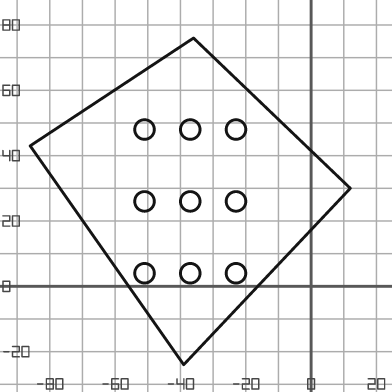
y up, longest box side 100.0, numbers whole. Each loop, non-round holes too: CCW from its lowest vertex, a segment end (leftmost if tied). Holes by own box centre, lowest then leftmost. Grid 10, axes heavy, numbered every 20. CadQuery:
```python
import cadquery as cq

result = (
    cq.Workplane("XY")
    .moveTo(-39.0, -24.0)
    .lineTo(12.0, 30.0)
    .lineTo(-36.0, 76.0)
    .lineTo(-86.0, 43.0)
    .close()
    .moveTo(-51.0, 4.0)
    .circle(3.0)
    .moveTo(-37.0, 4.0)
    .circle(3.0)
    .moveTo(-23.0, 4.0)
    .circle(3.0)
    .moveTo(-51.0, 26.0)
    .circle(3.0)
    .moveTo(-37.0, 26.0)
    .circle(3.0)
    .moveTo(-23.0, 26.0)
    .circle(3.0)
    .moveTo(-51.0, 48.0)
    .circle(3.0)
    .moveTo(-37.0, 48.0)
    .circle(3.0)
    .moveTo(-23.0, 48.0)
    .circle(3.0)
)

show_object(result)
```